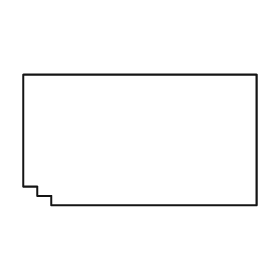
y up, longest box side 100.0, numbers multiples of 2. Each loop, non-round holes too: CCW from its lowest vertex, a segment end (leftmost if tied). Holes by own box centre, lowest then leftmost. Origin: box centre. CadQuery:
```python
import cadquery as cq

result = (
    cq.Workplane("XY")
    .moveTo(-38.0, -28.0)
    .lineTo(50.0, -28.0)
    .lineTo(50.0, 28.0)
    .lineTo(-50.0, 28.0)
    .lineTo(-50.0, -20.0)
    .lineTo(-44.0, -20.0)
    .lineTo(-44.0, -24.0)
    .lineTo(-38.0, -24.0)
    .close()
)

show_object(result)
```